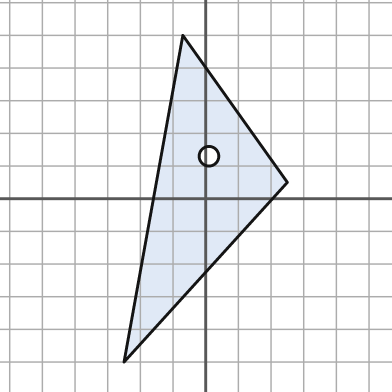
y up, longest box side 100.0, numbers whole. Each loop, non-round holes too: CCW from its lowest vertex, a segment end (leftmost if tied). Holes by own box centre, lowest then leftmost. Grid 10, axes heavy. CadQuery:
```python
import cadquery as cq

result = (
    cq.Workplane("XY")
    .moveTo(-25.0, -50.0)
    .lineTo(25.0, 5.0)
    .lineTo(-7.0, 50.0)
    .close()
    .moveTo(1.0, 13.0)
    .circle(3.0)
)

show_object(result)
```